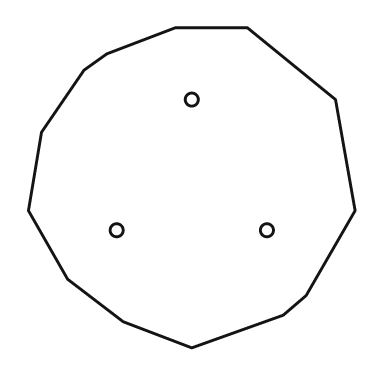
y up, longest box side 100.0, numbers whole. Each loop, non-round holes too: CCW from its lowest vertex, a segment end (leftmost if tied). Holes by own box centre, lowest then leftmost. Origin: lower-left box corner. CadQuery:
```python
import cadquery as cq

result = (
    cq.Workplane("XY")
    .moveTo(50.0, 0.0)
    .lineTo(78.0, 10.0)
    .lineTo(85.0, 16.0)
    .lineTo(100.0, 42.0)
    .lineTo(94.0, 76.0)
    .lineTo(67.0, 98.0)
    .lineTo(45.0, 98.0)
    .lineTo(24.0, 90.0)
    .lineTo(17.0, 85.0)
    .lineTo(4.0, 66.0)
    .lineTo(0.0, 42.0)
    .lineTo(12.0, 21.0)
    .lineTo(29.0, 8.0)
    .close()
    .moveTo(27.0, 36.0)
    .circle(2.0)
    .moveTo(73.0, 36.0)
    .circle(2.0)
    .moveTo(50.0, 76.0)
    .circle(2.0)
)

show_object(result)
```